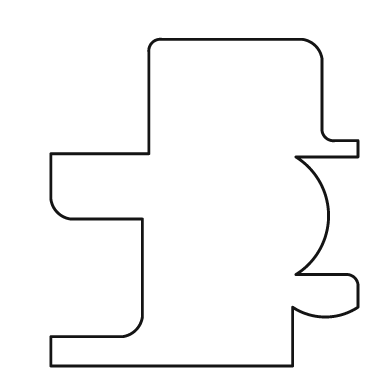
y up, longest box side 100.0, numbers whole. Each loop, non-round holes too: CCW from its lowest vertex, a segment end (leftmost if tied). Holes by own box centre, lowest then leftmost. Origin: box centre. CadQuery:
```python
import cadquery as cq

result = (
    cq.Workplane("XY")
    .moveTo(-47.0, -50.0)
    .lineTo(27.0, -50.0)
    .lineTo(27.0, -32.0)
    .threePointArc((37.0, -35.0), (47.0, -32.0))
    .lineTo(47.0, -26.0)
    .threePointArc((46.0, -23.0), (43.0, -22.0))
    .lineTo(28.0, -22.0)
    .threePointArc((38.0, -4.0), (28.0, 14.0))
    .lineTo(47.0, 14.0)
    .lineTo(47.0, 19.0)
    .lineTo(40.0, 19.0)
    .threePointArc((37.0, 20.0), (36.0, 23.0))
    .lineTo(36.0, 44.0)
    .threePointArc((34.0, 48.0), (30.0, 50.0))
    .lineTo(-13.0, 50.0)
    .threePointArc((-16.0, 49.0), (-17.0, 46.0))
    .lineTo(-17.0, 15.0)
    .lineTo(-47.0, 15.0)
    .lineTo(-47.0, 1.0)
    .threePointArc((-45.0, -3.0), (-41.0, -5.0))
    .lineTo(-19.0, -5.0)
    .lineTo(-19.0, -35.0)
    .threePointArc((-21.0, -39.0), (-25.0, -41.0))
    .lineTo(-47.0, -41.0)
    .close()
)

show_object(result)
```